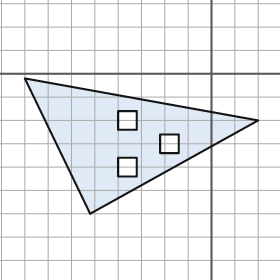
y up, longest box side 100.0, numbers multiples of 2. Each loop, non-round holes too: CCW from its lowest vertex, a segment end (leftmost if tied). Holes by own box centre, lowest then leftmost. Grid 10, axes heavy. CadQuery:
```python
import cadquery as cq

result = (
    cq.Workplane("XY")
    .moveTo(-52.0, -60.0)
    .lineTo(20.0, -20.0)
    .lineTo(-80.0, -2.0)
    .close()
    .moveTo(-40.0, -44.0)
    .lineTo(-32.0, -44.0)
    .lineTo(-32.0, -36.0)
    .lineTo(-40.0, -36.0)
    .close()
    .moveTo(-22.0, -34.0)
    .lineTo(-14.0, -34.0)
    .lineTo(-14.0, -26.0)
    .lineTo(-22.0, -26.0)
    .close()
    .moveTo(-40.0, -24.0)
    .lineTo(-32.0, -24.0)
    .lineTo(-32.0, -16.0)
    .lineTo(-40.0, -16.0)
    .close()
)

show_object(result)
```